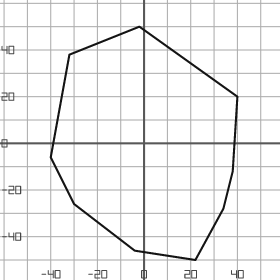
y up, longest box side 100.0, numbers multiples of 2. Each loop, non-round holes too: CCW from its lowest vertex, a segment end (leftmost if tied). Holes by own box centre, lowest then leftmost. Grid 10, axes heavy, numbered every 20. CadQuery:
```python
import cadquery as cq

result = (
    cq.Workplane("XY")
    .moveTo(22.0, -50.0)
    .lineTo(34.0, -28.0)
    .lineTo(38.0, -12.0)
    .lineTo(40.0, 20.0)
    .lineTo(-2.0, 50.0)
    .lineTo(-32.0, 38.0)
    .lineTo(-40.0, -6.0)
    .lineTo(-30.0, -26.0)
    .lineTo(-4.0, -46.0)
    .close()
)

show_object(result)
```